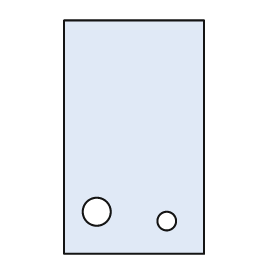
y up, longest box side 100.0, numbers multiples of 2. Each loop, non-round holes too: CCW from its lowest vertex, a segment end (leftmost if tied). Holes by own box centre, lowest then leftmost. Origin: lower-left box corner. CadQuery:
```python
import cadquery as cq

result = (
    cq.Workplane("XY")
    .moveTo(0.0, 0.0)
    .lineTo(60.0, 0.0)
    .lineTo(60.0, 100.0)
    .lineTo(0.0, 100.0)
    .close()
    .moveTo(44.0, 14.0)
    .circle(4.0)
    .moveTo(14.0, 18.0)
    .circle(6.0)
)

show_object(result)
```